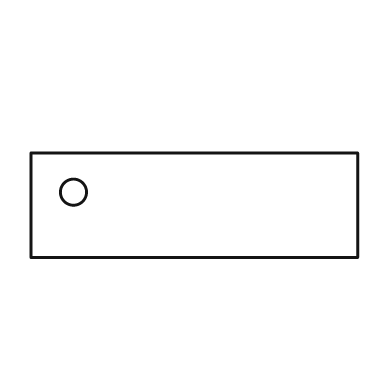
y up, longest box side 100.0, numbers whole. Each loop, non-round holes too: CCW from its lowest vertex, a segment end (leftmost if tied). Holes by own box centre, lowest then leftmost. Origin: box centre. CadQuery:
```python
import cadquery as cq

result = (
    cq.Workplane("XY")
    .moveTo(-50.0, -16.0)
    .lineTo(50.0, -16.0)
    .lineTo(50.0, 16.0)
    .lineTo(-50.0, 16.0)
    .close()
    .moveTo(-37.0, 4.0)
    .circle(4.0)
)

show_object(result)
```